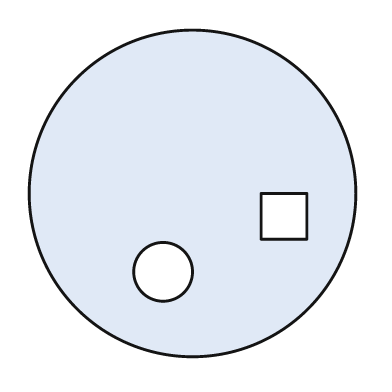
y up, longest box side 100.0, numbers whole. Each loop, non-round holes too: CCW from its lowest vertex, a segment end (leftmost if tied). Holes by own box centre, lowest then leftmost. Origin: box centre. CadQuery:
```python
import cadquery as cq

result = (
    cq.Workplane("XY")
    .moveTo(0.0, 0.0)
    .circle(50.0)
    .moveTo(-9.0, -24.0)
    .circle(9.0)
    .moveTo(21.0, -14.0)
    .lineTo(35.0, -14.0)
    .lineTo(35.0, 0.0)
    .lineTo(21.0, 0.0)
    .close()
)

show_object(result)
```